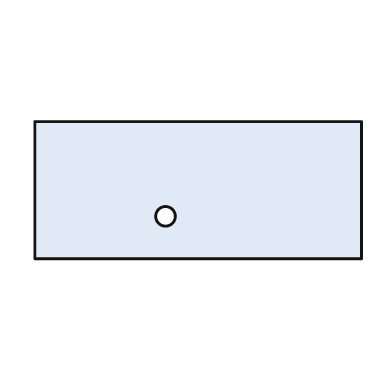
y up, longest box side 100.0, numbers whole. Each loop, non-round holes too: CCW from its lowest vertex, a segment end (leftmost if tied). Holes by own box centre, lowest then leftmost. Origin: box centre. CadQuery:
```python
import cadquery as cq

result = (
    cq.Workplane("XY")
    .moveTo(-50.0, -21.0)
    .lineTo(50.0, -21.0)
    .lineTo(50.0, 21.0)
    .lineTo(-50.0, 21.0)
    .close()
    .moveTo(-10.0, -8.0)
    .circle(3.0)
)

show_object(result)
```